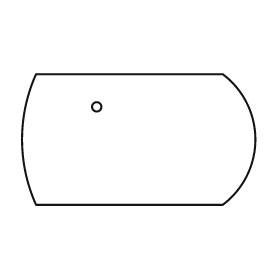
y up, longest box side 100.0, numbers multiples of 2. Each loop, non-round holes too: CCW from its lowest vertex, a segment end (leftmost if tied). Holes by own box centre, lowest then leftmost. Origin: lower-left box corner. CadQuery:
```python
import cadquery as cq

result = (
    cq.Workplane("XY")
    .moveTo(6.0, 0.0)
    .lineTo(86.0, 0.0)
    .threePointArc((100.0, 28.0), (86.0, 56.0))
    .lineTo(6.0, 56.0)
    .threePointArc((0.0, 28.0), (6.0, 0.0))
    .close()
    .moveTo(32.0, 42.0)
    .circle(2.0)
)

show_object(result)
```